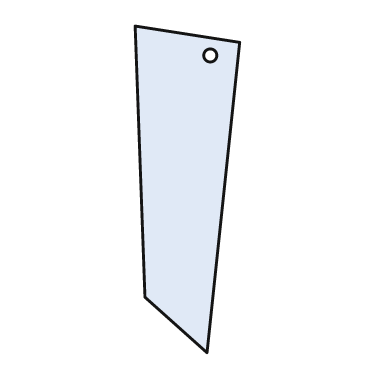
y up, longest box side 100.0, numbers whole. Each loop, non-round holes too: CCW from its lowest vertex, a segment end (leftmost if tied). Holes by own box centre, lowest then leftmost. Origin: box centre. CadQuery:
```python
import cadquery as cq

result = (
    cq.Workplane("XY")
    .moveTo(6.0, -50.0)
    .lineTo(16.0, 45.0)
    .lineTo(-16.0, 50.0)
    .lineTo(-13.0, -33.0)
    .close()
    .moveTo(7.0, 41.0)
    .circle(2.0)
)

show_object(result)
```